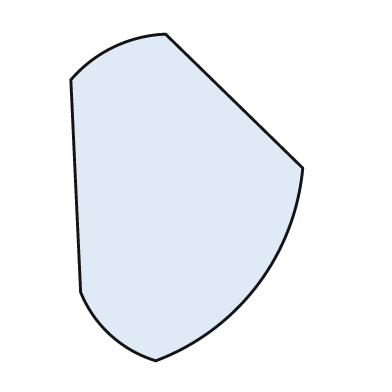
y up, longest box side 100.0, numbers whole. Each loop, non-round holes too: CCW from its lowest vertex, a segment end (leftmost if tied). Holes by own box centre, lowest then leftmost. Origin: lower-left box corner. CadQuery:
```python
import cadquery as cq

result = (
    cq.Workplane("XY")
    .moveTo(26.0, 0.0)
    .threePointArc((57.0, 23.0), (71.0, 59.0))
    .lineTo(29.0, 100.0)
    .threePointArc((13.0, 96.0), (0.0, 86.0))
    .lineTo(3.0, 21.0)
    .threePointArc((12.0, 8.0), (26.0, 0.0))
    .close()
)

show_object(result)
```